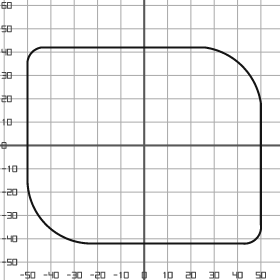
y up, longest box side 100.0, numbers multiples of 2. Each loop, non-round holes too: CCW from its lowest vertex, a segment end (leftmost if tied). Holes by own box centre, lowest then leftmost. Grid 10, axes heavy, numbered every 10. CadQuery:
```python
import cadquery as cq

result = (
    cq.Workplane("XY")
    .moveTo(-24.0, -42.0)
    .lineTo(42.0, -42.0)
    .threePointArc((48.0, -40.0), (50.0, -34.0))
    .lineTo(50.0, 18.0)
    .threePointArc((42.0, 34.0), (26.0, 42.0))
    .lineTo(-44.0, 42.0)
    .threePointArc((-48.0, 40.0), (-50.0, 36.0))
    .lineTo(-50.0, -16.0)
    .threePointArc((-42.0, -34.0), (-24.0, -42.0))
    .close()
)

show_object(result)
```